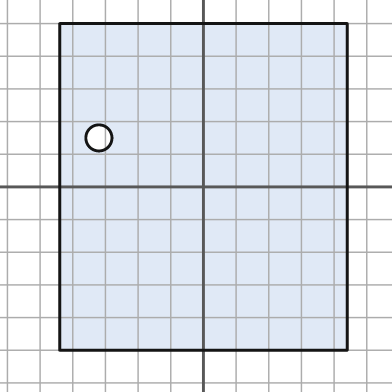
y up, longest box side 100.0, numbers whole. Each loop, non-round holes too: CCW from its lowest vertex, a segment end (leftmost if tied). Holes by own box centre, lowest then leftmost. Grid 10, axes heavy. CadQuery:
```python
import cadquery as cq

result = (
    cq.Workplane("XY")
    .moveTo(-44.0, -50.0)
    .lineTo(44.0, -50.0)
    .lineTo(44.0, 50.0)
    .lineTo(-44.0, 50.0)
    .close()
    .moveTo(-32.0, 15.0)
    .circle(4.0)
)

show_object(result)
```